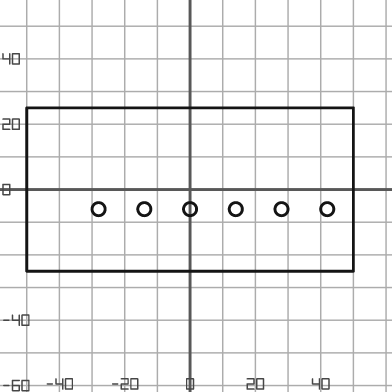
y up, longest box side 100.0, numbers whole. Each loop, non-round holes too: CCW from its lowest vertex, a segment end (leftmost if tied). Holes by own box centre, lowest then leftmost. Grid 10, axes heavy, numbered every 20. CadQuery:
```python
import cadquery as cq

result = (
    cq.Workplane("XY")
    .moveTo(-50.0, -25.0)
    .lineTo(50.0, -25.0)
    .lineTo(50.0, 25.0)
    .lineTo(-50.0, 25.0)
    .close()
    .moveTo(-28.0, -6.0)
    .circle(2.0)
    .moveTo(-14.0, -6.0)
    .circle(2.0)
    .moveTo(0.0, -6.0)
    .circle(2.0)
    .moveTo(14.0, -6.0)
    .circle(2.0)
    .moveTo(28.0, -6.0)
    .circle(2.0)
    .moveTo(42.0, -6.0)
    .circle(2.0)
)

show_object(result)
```